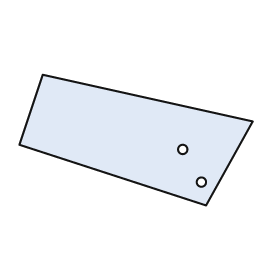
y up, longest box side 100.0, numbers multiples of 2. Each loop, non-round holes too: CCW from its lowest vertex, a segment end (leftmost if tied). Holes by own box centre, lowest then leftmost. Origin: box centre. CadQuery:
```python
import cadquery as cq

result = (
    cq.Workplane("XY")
    .moveTo(30.0, -28.0)
    .lineTo(50.0, 8.0)
    .lineTo(-40.0, 28.0)
    .lineTo(-50.0, -2.0)
    .close()
    .moveTo(28.0, -18.0)
    .circle(2.0)
    .moveTo(20.0, -4.0)
    .circle(2.0)
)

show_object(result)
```